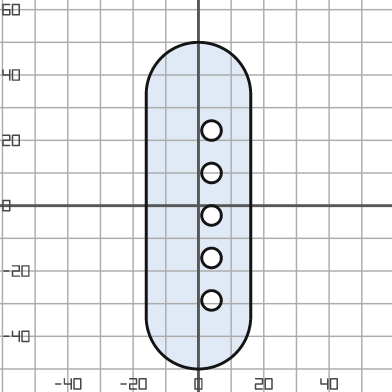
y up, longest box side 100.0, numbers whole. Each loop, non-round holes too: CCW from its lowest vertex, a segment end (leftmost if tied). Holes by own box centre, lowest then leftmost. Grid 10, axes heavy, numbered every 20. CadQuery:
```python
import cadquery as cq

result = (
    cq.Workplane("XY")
    .moveTo(-16.0, -34.0)
    .threePointArc((0.0, -50.0), (16.0, -34.0))
    .lineTo(16.0, 34.0)
    .threePointArc((0.0, 50.0), (-16.0, 34.0))
    .close()
    .moveTo(4.0, -29.0)
    .circle(3.0)
    .moveTo(4.0, -16.0)
    .circle(3.0)
    .moveTo(4.0, -3.0)
    .circle(3.0)
    .moveTo(4.0, 10.0)
    .circle(3.0)
    .moveTo(4.0, 23.0)
    .circle(3.0)
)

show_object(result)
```